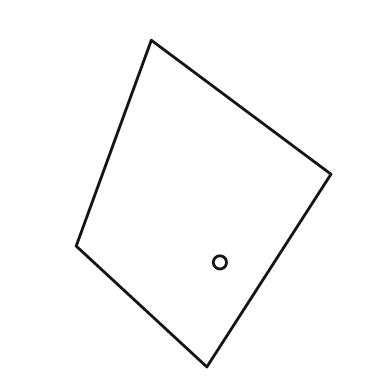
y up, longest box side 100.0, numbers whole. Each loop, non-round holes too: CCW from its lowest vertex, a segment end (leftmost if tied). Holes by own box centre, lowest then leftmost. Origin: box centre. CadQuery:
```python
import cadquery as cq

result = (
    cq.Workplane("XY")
    .moveTo(1.0, -50.0)
    .lineTo(39.0, 9.0)
    .lineTo(-16.0, 50.0)
    .lineTo(-39.0, -13.0)
    .close()
    .moveTo(5.0, -18.0)
    .circle(2.0)
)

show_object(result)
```